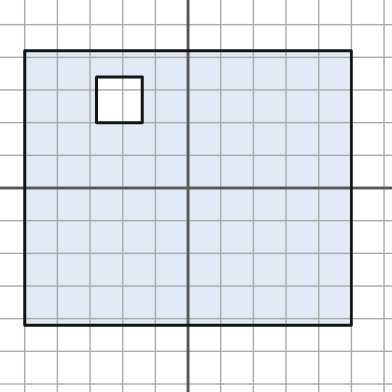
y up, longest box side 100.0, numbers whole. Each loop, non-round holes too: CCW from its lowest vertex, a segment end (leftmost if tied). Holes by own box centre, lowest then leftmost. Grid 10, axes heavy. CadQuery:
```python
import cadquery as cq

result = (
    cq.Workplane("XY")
    .moveTo(-50.0, -42.0)
    .lineTo(50.0, -42.0)
    .lineTo(50.0, 42.0)
    .lineTo(-50.0, 42.0)
    .close()
    .moveTo(-28.0, 20.0)
    .lineTo(-14.0, 20.0)
    .lineTo(-14.0, 34.0)
    .lineTo(-28.0, 34.0)
    .close()
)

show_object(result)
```